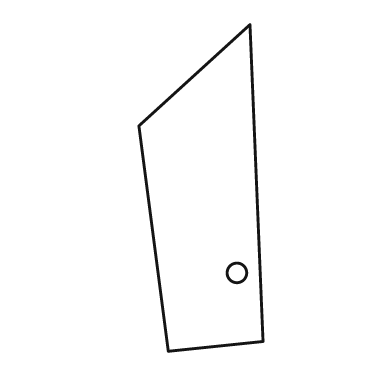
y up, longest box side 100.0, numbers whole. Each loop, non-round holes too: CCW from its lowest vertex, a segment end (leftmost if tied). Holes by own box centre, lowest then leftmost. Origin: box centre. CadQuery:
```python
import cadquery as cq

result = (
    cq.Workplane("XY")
    .moveTo(-10.0, -50.0)
    .lineTo(19.0, -47.0)
    .lineTo(15.0, 50.0)
    .lineTo(-19.0, 19.0)
    .close()
    .moveTo(11.0, -26.0)
    .circle(3.0)
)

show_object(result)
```